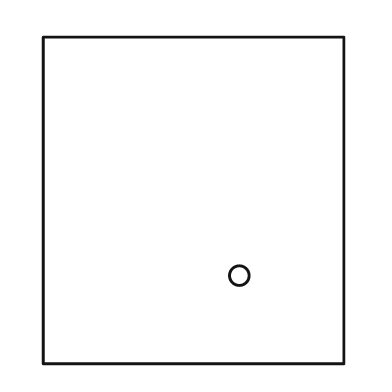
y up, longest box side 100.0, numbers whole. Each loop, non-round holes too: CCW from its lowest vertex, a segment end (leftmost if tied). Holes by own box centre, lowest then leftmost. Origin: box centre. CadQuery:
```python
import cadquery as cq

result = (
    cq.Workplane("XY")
    .moveTo(-46.0, -50.0)
    .lineTo(46.0, -50.0)
    .lineTo(46.0, 50.0)
    .lineTo(-46.0, 50.0)
    .close()
    .moveTo(14.0, -23.0)
    .circle(3.0)
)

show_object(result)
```